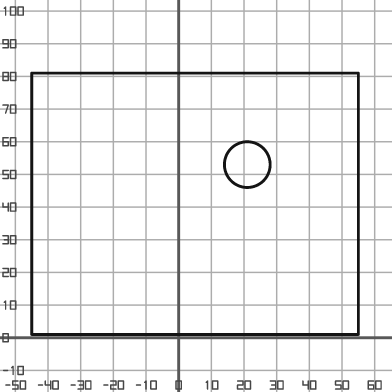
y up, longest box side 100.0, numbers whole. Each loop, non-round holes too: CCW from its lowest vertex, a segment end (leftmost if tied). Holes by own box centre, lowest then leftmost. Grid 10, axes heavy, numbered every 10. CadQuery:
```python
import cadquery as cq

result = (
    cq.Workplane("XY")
    .moveTo(-45.0, 1.0)
    .lineTo(55.0, 1.0)
    .lineTo(55.0, 81.0)
    .lineTo(-45.0, 81.0)
    .close()
    .moveTo(21.0, 53.0)
    .circle(7.0)
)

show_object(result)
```